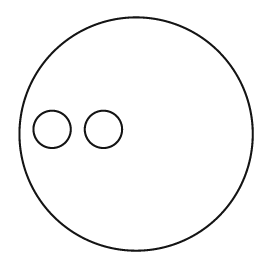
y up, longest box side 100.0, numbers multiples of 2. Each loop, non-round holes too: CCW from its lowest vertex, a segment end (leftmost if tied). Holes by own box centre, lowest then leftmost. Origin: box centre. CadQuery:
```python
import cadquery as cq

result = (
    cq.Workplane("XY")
    .moveTo(0.0, 0.0)
    .circle(50.0)
    .moveTo(-36.0, 2.0)
    .circle(8.0)
    .moveTo(-14.0, 2.0)
    .circle(8.0)
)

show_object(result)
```